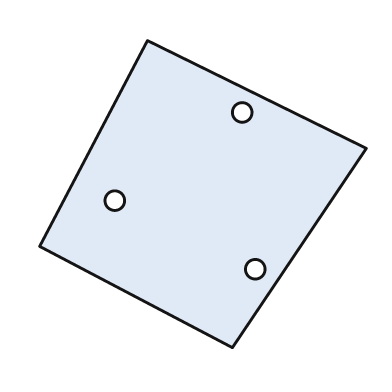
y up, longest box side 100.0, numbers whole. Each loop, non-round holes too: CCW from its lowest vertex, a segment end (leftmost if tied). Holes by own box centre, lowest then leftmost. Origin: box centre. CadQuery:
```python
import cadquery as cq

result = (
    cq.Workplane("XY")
    .moveTo(9.0, -47.0)
    .lineTo(50.0, 14.0)
    .lineTo(-17.0, 47.0)
    .lineTo(-50.0, -16.0)
    .close()
    .moveTo(16.0, -23.0)
    .circle(3.0)
    .moveTo(-27.0, -2.0)
    .circle(3.0)
    .moveTo(12.0, 25.0)
    .circle(3.0)
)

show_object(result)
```